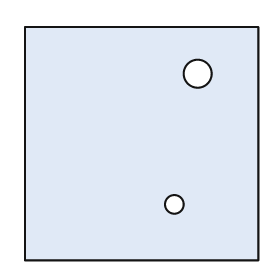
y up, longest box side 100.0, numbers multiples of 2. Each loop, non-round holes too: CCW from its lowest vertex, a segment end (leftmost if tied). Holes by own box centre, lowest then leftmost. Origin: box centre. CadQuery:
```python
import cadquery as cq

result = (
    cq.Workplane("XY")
    .moveTo(-50.0, -50.0)
    .lineTo(50.0, -50.0)
    .lineTo(50.0, 50.0)
    .lineTo(-50.0, 50.0)
    .close()
    .moveTo(14.0, -26.0)
    .circle(4.0)
    .moveTo(24.0, 30.0)
    .circle(6.0)
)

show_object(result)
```